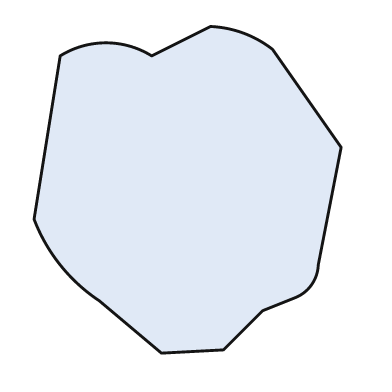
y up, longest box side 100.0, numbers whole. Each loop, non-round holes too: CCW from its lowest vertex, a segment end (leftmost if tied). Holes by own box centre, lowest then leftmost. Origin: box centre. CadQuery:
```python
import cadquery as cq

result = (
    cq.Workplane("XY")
    .moveTo(-8.0, -50.0)
    .lineTo(11.0, -49.0)
    .lineTo(23.0, -37.0)
    .lineTo(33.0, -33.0)
    .threePointArc((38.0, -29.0), (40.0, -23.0))
    .lineTo(47.0, 13.0)
    .lineTo(26.0, 43.0)
    .threePointArc((17.0, 48.0), (7.0, 50.0))
    .lineTo(-11.0, 41.0)
    .threePointArc((-25.0, 45.0), (-39.0, 41.0))
    .lineTo(-47.0, -9.0)
    .threePointArc((-39.0, -23.0), (-27.0, -34.0))
    .close()
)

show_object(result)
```